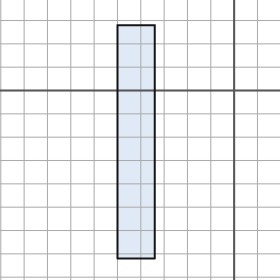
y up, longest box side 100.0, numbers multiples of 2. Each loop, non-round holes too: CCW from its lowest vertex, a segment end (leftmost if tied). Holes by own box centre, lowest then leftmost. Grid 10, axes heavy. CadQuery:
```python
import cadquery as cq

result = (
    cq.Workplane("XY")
    .moveTo(-50.0, -72.0)
    .lineTo(-34.0, -72.0)
    .lineTo(-34.0, 28.0)
    .lineTo(-50.0, 28.0)
    .close()
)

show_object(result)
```